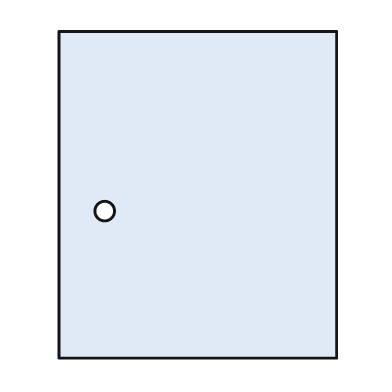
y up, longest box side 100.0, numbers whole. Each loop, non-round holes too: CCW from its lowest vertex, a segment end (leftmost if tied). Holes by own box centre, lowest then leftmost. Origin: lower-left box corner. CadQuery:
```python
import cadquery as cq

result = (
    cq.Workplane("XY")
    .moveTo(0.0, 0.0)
    .lineTo(85.0, 0.0)
    .lineTo(85.0, 100.0)
    .lineTo(0.0, 100.0)
    .close()
    .moveTo(14.0, 45.0)
    .circle(3.0)
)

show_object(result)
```